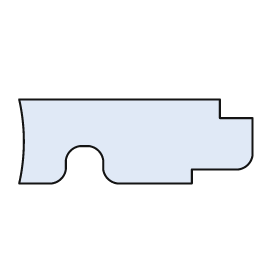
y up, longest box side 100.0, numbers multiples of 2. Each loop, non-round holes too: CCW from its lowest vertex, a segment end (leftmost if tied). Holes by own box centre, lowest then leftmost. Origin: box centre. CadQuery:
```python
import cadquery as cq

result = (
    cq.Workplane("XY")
    .moveTo(-50.0, -18.0)
    .lineTo(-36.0, -18.0)
    .threePointArc((-32.0, -16.0), (-30.0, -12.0))
    .lineTo(-30.0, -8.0)
    .threePointArc((-28.0, -4.0), (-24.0, -2.0))
    .lineTo(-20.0, -2.0)
    .threePointArc((-16.0, -4.0), (-14.0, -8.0))
    .lineTo(-14.0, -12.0)
    .threePointArc((-12.0, -16.0), (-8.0, -18.0))
    .lineTo(24.0, -18.0)
    .lineTo(24.0, -12.0)
    .lineTo(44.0, -12.0)
    .threePointArc((48.0, -10.0), (50.0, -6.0))
    .lineTo(50.0, 10.0)
    .lineTo(36.0, 10.0)
    .lineTo(36.0, 18.0)
    .lineTo(-50.0, 18.0)
    .threePointArc((-48.0, 0.0), (-50.0, -18.0))
    .close()
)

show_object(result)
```